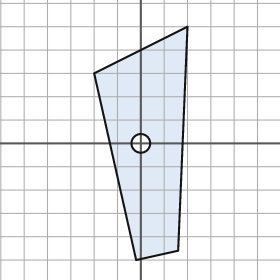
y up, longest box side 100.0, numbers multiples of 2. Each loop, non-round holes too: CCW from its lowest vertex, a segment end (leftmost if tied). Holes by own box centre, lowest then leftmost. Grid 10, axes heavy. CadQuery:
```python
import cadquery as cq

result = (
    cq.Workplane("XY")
    .moveTo(-2.0, -50.0)
    .lineTo(16.0, -46.0)
    .lineTo(20.0, 50.0)
    .lineTo(-20.0, 30.0)
    .close()
    .moveTo(0.0, 0.0)
    .circle(4.0)
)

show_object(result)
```